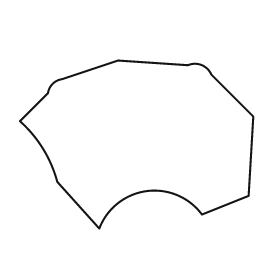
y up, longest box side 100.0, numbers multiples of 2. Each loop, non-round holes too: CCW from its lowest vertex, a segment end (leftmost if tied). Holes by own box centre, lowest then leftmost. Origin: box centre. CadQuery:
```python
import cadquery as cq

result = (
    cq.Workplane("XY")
    .moveTo(-16.0, -36.0)
    .threePointArc((4.0, -20.0), (28.0, -30.0))
    .lineTo(48.0, -22.0)
    .lineTo(50.0, 12.0)
    .lineTo(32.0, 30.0)
    .threePointArc((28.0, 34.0), (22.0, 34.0))
    .lineTo(-8.0, 36.0)
    .lineTo(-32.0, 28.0)
    .threePointArc((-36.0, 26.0), (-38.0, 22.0))
    .lineTo(-50.0, 10.0)
    .threePointArc((-40.0, -2.0), (-34.0, -16.0))
    .close()
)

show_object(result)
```